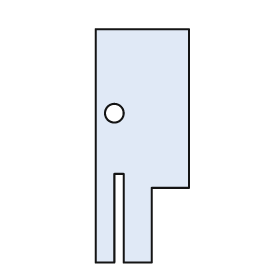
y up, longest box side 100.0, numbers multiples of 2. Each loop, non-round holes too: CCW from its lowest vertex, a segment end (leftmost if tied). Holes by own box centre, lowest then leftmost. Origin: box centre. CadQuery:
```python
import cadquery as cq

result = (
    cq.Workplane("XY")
    .moveTo(-20.0, -50.0)
    .lineTo(-12.0, -50.0)
    .lineTo(-12.0, -12.0)
    .lineTo(-8.0, -12.0)
    .lineTo(-8.0, -50.0)
    .lineTo(4.0, -50.0)
    .lineTo(4.0, -18.0)
    .lineTo(20.0, -18.0)
    .lineTo(20.0, 50.0)
    .lineTo(-20.0, 50.0)
    .close()
    .moveTo(-12.0, 14.0)
    .circle(4.0)
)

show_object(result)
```